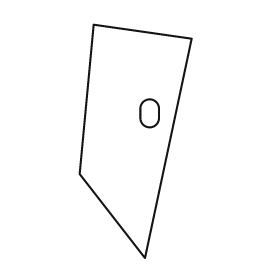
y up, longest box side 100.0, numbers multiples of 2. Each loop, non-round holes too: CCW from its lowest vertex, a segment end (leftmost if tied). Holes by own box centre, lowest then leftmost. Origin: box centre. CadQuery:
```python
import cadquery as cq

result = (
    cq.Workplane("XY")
    .moveTo(4.0, -50.0)
    .lineTo(24.0, 44.0)
    .lineTo(-18.0, 50.0)
    .lineTo(-24.0, -14.0)
    .close()
    .moveTo(2.0, 10.0)
    .threePointArc((6.0, 6.0), (10.0, 10.0))
    .lineTo(10.0, 14.0)
    .threePointArc((6.0, 18.0), (2.0, 14.0))
    .close()
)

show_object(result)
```